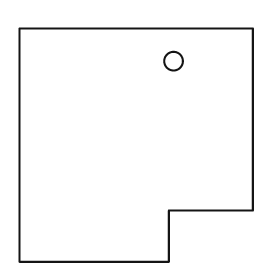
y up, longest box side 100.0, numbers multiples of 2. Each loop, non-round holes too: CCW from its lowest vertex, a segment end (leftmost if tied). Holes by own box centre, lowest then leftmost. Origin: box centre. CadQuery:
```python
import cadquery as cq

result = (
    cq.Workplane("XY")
    .moveTo(-50.0, -50.0)
    .lineTo(14.0, -50.0)
    .lineTo(14.0, -28.0)
    .lineTo(50.0, -28.0)
    .lineTo(50.0, 50.0)
    .lineTo(-50.0, 50.0)
    .close()
    .moveTo(16.0, 36.0)
    .circle(4.0)
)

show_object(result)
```